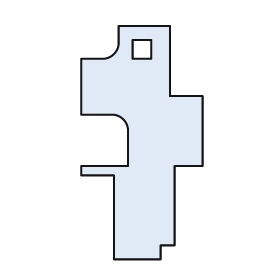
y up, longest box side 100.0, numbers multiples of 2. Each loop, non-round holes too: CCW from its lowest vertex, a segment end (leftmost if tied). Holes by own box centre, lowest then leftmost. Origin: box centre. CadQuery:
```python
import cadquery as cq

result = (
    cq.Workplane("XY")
    .moveTo(-12.0, -50.0)
    .lineTo(8.0, -50.0)
    .lineTo(8.0, -44.0)
    .lineTo(14.0, -44.0)
    .lineTo(14.0, -10.0)
    .lineTo(26.0, -10.0)
    .lineTo(26.0, 20.0)
    .lineTo(12.0, 20.0)
    .lineTo(12.0, 50.0)
    .lineTo(-10.0, 50.0)
    .lineTo(-10.0, 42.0)
    .threePointArc((-12.0, 38.0), (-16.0, 36.0))
    .lineTo(-26.0, 36.0)
    .lineTo(-26.0, 12.0)
    .lineTo(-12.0, 12.0)
    .threePointArc((-8.0, 10.0), (-6.0, 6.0))
    .lineTo(-6.0, -10.0)
    .lineTo(-26.0, -10.0)
    .lineTo(-26.0, -14.0)
    .lineTo(-12.0, -14.0)
    .close()
    .moveTo(-4.0, 36.0)
    .lineTo(4.0, 36.0)
    .lineTo(4.0, 44.0)
    .lineTo(-4.0, 44.0)
    .close()
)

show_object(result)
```